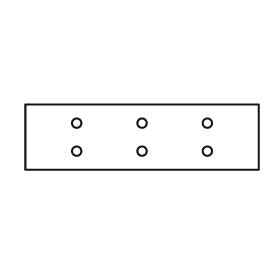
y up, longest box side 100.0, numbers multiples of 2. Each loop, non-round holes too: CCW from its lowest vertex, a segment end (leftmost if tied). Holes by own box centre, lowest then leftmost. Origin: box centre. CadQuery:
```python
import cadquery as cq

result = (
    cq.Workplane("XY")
    .moveTo(-50.0, -14.0)
    .lineTo(50.0, -14.0)
    .lineTo(50.0, 14.0)
    .lineTo(-50.0, 14.0)
    .close()
    .moveTo(-28.0, -6.0)
    .circle(2.0)
    .moveTo(0.0, -6.0)
    .circle(2.0)
    .moveTo(28.0, -6.0)
    .circle(2.0)
    .moveTo(-28.0, 6.0)
    .circle(2.0)
    .moveTo(0.0, 6.0)
    .circle(2.0)
    .moveTo(28.0, 6.0)
    .circle(2.0)
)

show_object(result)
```